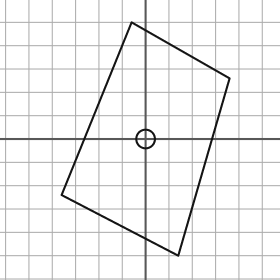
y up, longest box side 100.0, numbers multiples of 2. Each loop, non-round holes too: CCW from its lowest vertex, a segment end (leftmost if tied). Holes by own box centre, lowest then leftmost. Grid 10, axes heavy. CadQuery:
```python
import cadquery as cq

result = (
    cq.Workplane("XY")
    .moveTo(14.0, -50.0)
    .lineTo(36.0, 26.0)
    .lineTo(-6.0, 50.0)
    .lineTo(-36.0, -24.0)
    .close()
    .moveTo(0.0, 0.0)
    .circle(4.0)
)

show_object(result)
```